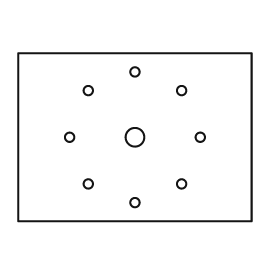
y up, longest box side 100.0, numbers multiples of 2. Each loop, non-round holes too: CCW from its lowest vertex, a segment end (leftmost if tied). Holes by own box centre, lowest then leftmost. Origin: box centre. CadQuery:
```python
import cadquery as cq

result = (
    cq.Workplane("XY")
    .moveTo(-50.0, -36.0)
    .lineTo(50.0, -36.0)
    .lineTo(50.0, 36.0)
    .lineTo(-50.0, 36.0)
    .close()
    .moveTo(0.0, -28.0)
    .circle(2.0)
    .moveTo(-20.0, -20.0)
    .circle(2.0)
    .moveTo(20.0, -20.0)
    .circle(2.0)
    .moveTo(-28.0, 0.0)
    .circle(2.0)
    .moveTo(0.0, 0.0)
    .circle(4.0)
    .moveTo(28.0, 0.0)
    .circle(2.0)
    .moveTo(-20.0, 20.0)
    .circle(2.0)
    .moveTo(20.0, 20.0)
    .circle(2.0)
    .moveTo(0.0, 28.0)
    .circle(2.0)
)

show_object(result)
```